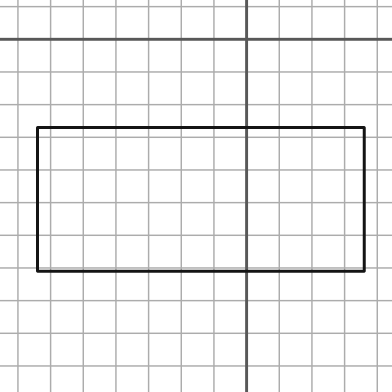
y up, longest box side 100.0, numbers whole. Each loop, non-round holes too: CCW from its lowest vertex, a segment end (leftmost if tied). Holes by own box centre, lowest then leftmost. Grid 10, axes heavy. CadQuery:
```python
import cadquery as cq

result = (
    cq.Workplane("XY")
    .moveTo(-64.0, -71.0)
    .lineTo(36.0, -71.0)
    .lineTo(36.0, -27.0)
    .lineTo(-64.0, -27.0)
    .close()
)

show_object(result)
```